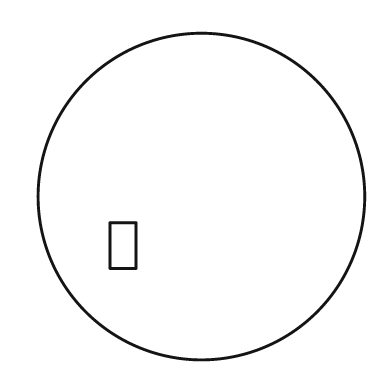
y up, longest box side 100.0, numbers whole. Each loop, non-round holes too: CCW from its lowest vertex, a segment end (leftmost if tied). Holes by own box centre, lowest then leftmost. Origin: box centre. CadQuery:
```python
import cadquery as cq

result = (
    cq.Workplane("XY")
    .moveTo(0.0, 0.0)
    .circle(50.0)
    .moveTo(-28.0, -22.0)
    .lineTo(-20.0, -22.0)
    .lineTo(-20.0, -8.0)
    .lineTo(-28.0, -8.0)
    .close()
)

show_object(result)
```